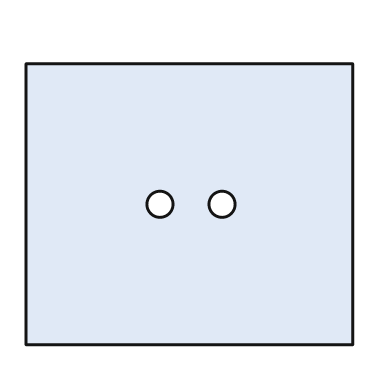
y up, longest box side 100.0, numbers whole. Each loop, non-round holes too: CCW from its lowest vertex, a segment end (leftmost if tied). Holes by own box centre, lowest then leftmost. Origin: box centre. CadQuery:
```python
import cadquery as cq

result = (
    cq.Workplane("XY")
    .moveTo(-50.0, -43.0)
    .lineTo(50.0, -43.0)
    .lineTo(50.0, 43.0)
    .lineTo(-50.0, 43.0)
    .close()
    .moveTo(-9.0, 0.0)
    .circle(4.0)
    .moveTo(10.0, 0.0)
    .circle(4.0)
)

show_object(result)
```